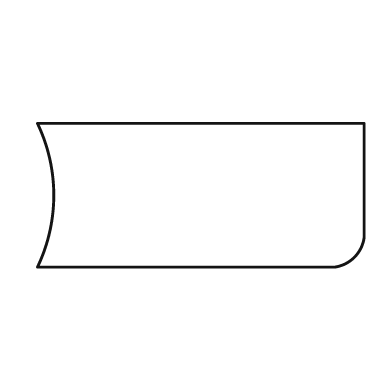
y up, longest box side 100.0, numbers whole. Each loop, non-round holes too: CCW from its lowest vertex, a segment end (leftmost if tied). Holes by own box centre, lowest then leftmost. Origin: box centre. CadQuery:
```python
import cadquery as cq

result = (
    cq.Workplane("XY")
    .moveTo(-50.0, -22.0)
    .lineTo(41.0, -22.0)
    .threePointArc((47.0, -19.0), (50.0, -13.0))
    .lineTo(50.0, 22.0)
    .lineTo(-50.0, 22.0)
    .threePointArc((-45.0, 0.0), (-50.0, -22.0))
    .close()
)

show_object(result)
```